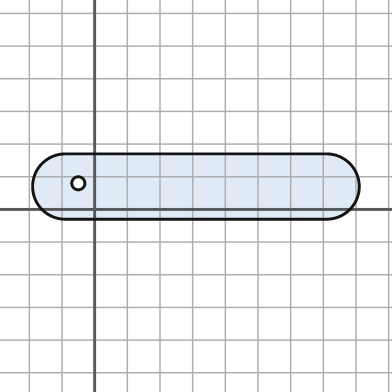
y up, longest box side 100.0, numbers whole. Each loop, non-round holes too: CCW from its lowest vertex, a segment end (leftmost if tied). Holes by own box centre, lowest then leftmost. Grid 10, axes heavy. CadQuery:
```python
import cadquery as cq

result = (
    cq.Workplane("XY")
    .moveTo(-9.0, -3.0)
    .lineTo(71.0, -3.0)
    .threePointArc((81.0, 7.0), (71.0, 17.0))
    .lineTo(-9.0, 17.0)
    .threePointArc((-19.0, 7.0), (-9.0, -3.0))
    .close()
    .moveTo(-5.0, 8.0)
    .circle(2.0)
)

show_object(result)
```